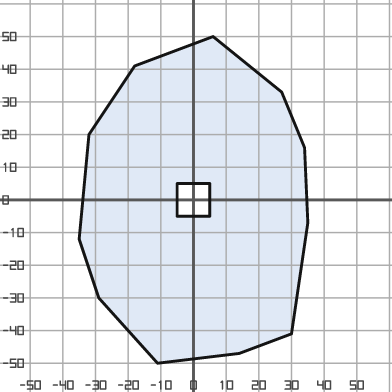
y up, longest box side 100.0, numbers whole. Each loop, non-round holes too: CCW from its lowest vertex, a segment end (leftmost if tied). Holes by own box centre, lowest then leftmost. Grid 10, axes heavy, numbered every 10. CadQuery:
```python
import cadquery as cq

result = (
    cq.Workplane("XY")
    .moveTo(-11.0, -50.0)
    .lineTo(14.0, -47.0)
    .lineTo(30.0, -41.0)
    .lineTo(35.0, -7.0)
    .lineTo(34.0, 16.0)
    .lineTo(27.0, 33.0)
    .lineTo(6.0, 50.0)
    .lineTo(-18.0, 41.0)
    .lineTo(-32.0, 20.0)
    .lineTo(-35.0, -12.0)
    .lineTo(-29.0, -30.0)
    .close()
    .moveTo(-5.0, -5.0)
    .lineTo(5.0, -5.0)
    .lineTo(5.0, 5.0)
    .lineTo(-5.0, 5.0)
    .close()
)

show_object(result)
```